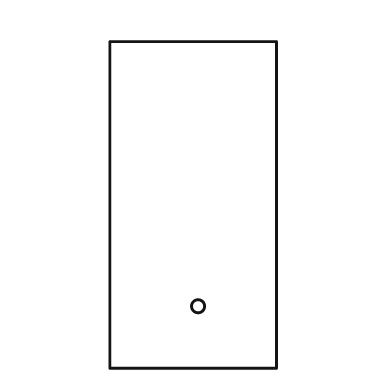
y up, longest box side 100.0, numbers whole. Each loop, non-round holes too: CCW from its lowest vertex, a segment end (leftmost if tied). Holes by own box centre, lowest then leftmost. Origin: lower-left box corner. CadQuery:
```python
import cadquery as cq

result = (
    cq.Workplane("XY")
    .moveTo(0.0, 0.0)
    .lineTo(51.0, 0.0)
    .lineTo(51.0, 100.0)
    .lineTo(0.0, 100.0)
    .close()
    .moveTo(27.0, 19.0)
    .circle(2.0)
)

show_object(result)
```